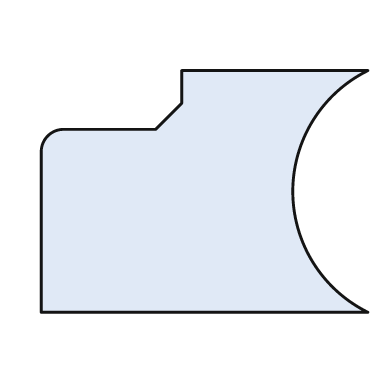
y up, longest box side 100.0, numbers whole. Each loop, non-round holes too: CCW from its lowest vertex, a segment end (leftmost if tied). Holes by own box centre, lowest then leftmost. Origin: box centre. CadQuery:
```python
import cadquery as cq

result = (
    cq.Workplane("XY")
    .moveTo(-50.0, -37.0)
    .lineTo(50.0, -37.0)
    .threePointArc((27.0, 0.0), (50.0, 37.0))
    .lineTo(-7.0, 37.0)
    .lineTo(-7.0, 27.0)
    .lineTo(-15.0, 19.0)
    .lineTo(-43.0, 19.0)
    .threePointArc((-48.0, 17.0), (-50.0, 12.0))
    .close()
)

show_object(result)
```